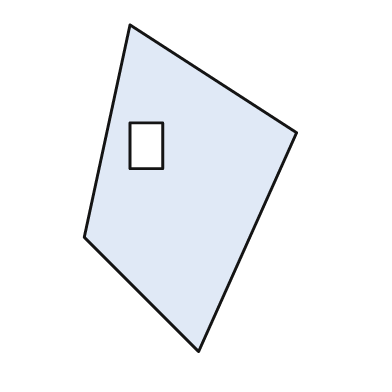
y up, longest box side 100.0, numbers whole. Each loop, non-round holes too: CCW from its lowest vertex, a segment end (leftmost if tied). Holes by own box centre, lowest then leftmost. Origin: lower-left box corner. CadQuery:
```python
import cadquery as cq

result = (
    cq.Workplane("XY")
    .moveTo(35.0, 0.0)
    .lineTo(65.0, 67.0)
    .lineTo(14.0, 100.0)
    .lineTo(0.0, 35.0)
    .close()
    .moveTo(14.0, 56.0)
    .lineTo(24.0, 56.0)
    .lineTo(24.0, 70.0)
    .lineTo(14.0, 70.0)
    .close()
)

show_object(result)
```